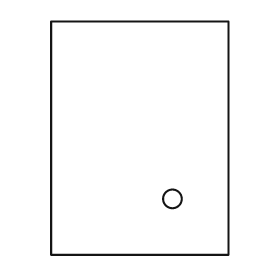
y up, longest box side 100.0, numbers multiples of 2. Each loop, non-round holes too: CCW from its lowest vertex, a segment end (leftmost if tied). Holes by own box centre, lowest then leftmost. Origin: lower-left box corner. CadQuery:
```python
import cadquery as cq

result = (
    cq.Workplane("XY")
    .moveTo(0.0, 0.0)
    .lineTo(76.0, 0.0)
    .lineTo(76.0, 100.0)
    .lineTo(0.0, 100.0)
    .close()
    .moveTo(52.0, 24.0)
    .circle(4.0)
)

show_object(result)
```